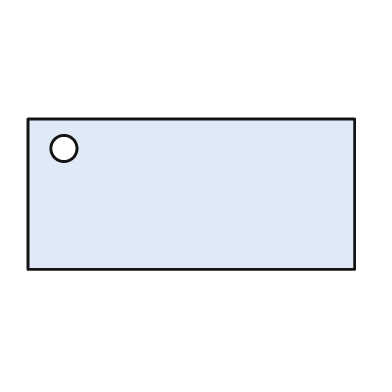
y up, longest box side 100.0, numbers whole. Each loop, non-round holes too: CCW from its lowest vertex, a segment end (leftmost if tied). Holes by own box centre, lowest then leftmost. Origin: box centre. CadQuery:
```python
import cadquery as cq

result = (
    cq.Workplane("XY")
    .moveTo(-50.0, -23.0)
    .lineTo(50.0, -23.0)
    .lineTo(50.0, 23.0)
    .lineTo(-50.0, 23.0)
    .close()
    .moveTo(-39.0, 14.0)
    .circle(4.0)
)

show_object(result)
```